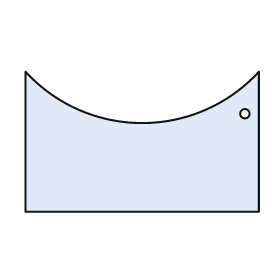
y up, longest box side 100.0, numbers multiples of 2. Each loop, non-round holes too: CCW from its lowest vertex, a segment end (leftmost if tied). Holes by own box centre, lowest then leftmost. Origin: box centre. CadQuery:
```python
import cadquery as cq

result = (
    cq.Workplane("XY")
    .moveTo(-50.0, -30.0)
    .lineTo(50.0, -30.0)
    .lineTo(50.0, 30.0)
    .threePointArc((0.0, 8.0), (-50.0, 30.0))
    .close()
    .moveTo(44.0, 12.0)
    .circle(2.0)
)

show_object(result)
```